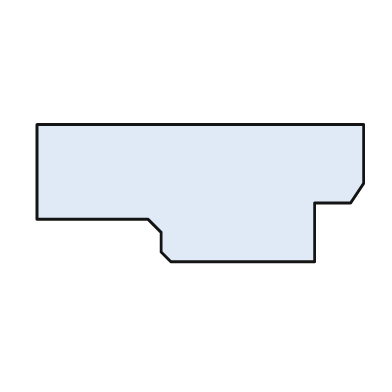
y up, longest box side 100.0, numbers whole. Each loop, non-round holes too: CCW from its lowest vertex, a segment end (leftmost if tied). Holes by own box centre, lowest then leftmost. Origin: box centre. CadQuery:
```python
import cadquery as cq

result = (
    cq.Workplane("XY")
    .moveTo(-9.0, -21.0)
    .lineTo(35.0, -21.0)
    .lineTo(35.0, -3.0)
    .lineTo(46.0, -3.0)
    .lineTo(50.0, 3.0)
    .lineTo(50.0, 21.0)
    .lineTo(-50.0, 21.0)
    .lineTo(-50.0, -8.0)
    .lineTo(-16.0, -8.0)
    .lineTo(-12.0, -12.0)
    .lineTo(-12.0, -18.0)
    .close()
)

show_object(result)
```